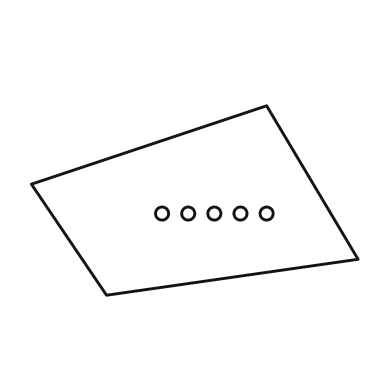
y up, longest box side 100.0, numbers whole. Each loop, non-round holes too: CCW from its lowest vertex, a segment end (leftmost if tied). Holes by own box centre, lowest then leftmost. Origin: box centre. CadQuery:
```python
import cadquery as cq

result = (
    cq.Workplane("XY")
    .moveTo(-27.0, -29.0)
    .lineTo(50.0, -18.0)
    .lineTo(22.0, 29.0)
    .lineTo(-50.0, 5.0)
    .close()
    .moveTo(-10.0, -4.0)
    .circle(2.0)
    .moveTo(-2.0, -4.0)
    .circle(2.0)
    .moveTo(6.0, -4.0)
    .circle(2.0)
    .moveTo(14.0, -4.0)
    .circle(2.0)
    .moveTo(22.0, -4.0)
    .circle(2.0)
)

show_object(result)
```